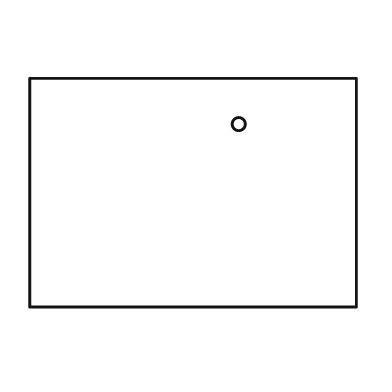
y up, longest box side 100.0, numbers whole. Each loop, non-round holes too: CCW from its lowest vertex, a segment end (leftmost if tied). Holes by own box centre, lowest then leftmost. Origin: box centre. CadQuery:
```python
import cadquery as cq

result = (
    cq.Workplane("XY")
    .moveTo(-50.0, -35.0)
    .lineTo(50.0, -35.0)
    .lineTo(50.0, 35.0)
    .lineTo(-50.0, 35.0)
    .close()
    .moveTo(14.0, 21.0)
    .circle(2.0)
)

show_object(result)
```